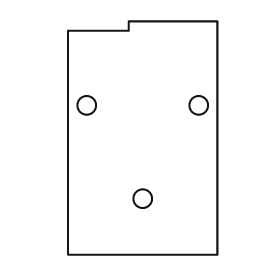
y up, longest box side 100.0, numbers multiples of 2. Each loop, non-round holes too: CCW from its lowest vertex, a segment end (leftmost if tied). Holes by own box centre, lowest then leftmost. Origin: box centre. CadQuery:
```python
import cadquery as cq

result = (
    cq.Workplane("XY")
    .moveTo(-32.0, -50.0)
    .lineTo(32.0, -50.0)
    .lineTo(32.0, 50.0)
    .lineTo(-6.0, 50.0)
    .lineTo(-6.0, 46.0)
    .lineTo(-32.0, 46.0)
    .close()
    .moveTo(0.0, -26.0)
    .circle(4.0)
    .moveTo(-24.0, 14.0)
    .circle(4.0)
    .moveTo(24.0, 14.0)
    .circle(4.0)
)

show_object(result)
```